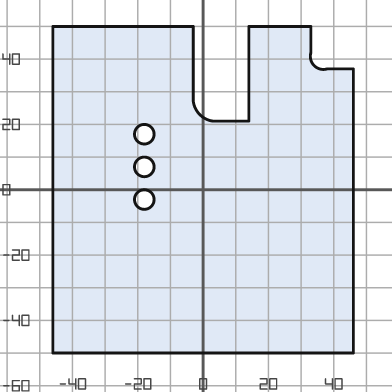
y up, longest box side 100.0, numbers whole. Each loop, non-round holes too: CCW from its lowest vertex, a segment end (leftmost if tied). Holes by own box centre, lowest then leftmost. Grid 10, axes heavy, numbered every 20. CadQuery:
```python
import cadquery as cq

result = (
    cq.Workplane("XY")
    .moveTo(-46.0, -50.0)
    .lineTo(46.0, -50.0)
    .lineTo(46.0, 37.0)
    .lineTo(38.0, 37.0)
    .threePointArc((34.0, 38.0), (33.0, 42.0))
    .lineTo(33.0, 50.0)
    .lineTo(14.0, 50.0)
    .lineTo(14.0, 21.0)
    .lineTo(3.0, 21.0)
    .threePointArc((-1.0, 23.0), (-3.0, 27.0))
    .lineTo(-3.0, 50.0)
    .lineTo(-46.0, 50.0)
    .close()
    .moveTo(-18.0, -3.0)
    .circle(3.0)
    .moveTo(-18.0, 7.0)
    .circle(3.0)
    .moveTo(-18.0, 17.0)
    .circle(3.0)
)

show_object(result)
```